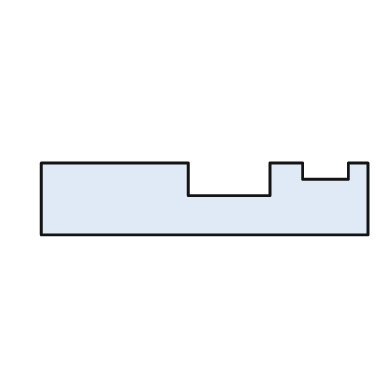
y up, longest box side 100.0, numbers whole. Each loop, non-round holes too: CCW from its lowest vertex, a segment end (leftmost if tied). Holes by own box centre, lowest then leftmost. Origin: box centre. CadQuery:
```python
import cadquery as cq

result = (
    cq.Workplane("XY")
    .moveTo(-50.0, -11.0)
    .lineTo(50.0, -11.0)
    .lineTo(50.0, 11.0)
    .lineTo(44.0, 11.0)
    .lineTo(44.0, 6.0)
    .lineTo(30.0, 6.0)
    .lineTo(30.0, 11.0)
    .lineTo(20.0, 11.0)
    .lineTo(20.0, 1.0)
    .lineTo(-5.0, 1.0)
    .lineTo(-5.0, 11.0)
    .lineTo(-50.0, 11.0)
    .close()
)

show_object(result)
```